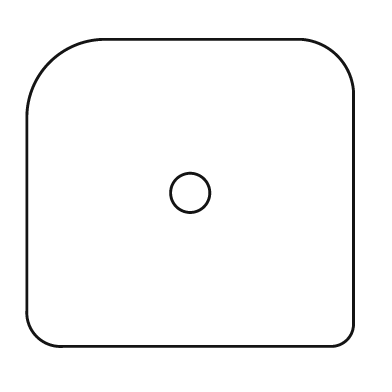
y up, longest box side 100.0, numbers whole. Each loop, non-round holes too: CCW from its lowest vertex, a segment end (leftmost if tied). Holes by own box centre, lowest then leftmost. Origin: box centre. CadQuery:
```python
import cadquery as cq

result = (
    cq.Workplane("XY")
    .moveTo(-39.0, -47.0)
    .lineTo(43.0, -47.0)
    .threePointArc((48.0, -45.0), (50.0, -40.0))
    .lineTo(50.0, 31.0)
    .threePointArc((45.0, 42.0), (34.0, 47.0))
    .lineTo(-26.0, 47.0)
    .threePointArc((-43.0, 40.0), (-50.0, 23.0))
    .lineTo(-50.0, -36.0)
    .threePointArc((-47.0, -44.0), (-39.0, -47.0))
    .close()
    .moveTo(0.0, 0.0)
    .circle(6.0)
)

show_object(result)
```